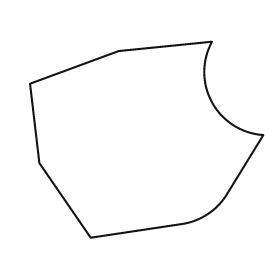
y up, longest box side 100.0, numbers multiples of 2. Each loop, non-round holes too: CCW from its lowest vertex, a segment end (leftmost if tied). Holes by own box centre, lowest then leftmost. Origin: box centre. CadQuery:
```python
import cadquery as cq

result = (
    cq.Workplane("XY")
    .moveTo(-24.0, -42.0)
    .lineTo(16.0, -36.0)
    .threePointArc((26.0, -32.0), (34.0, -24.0))
    .lineTo(50.0, 2.0)
    .threePointArc((28.0, 16.0), (28.0, 42.0))
    .lineTo(-12.0, 38.0)
    .lineTo(-50.0, 24.0)
    .lineTo(-46.0, -10.0)
    .close()
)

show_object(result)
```